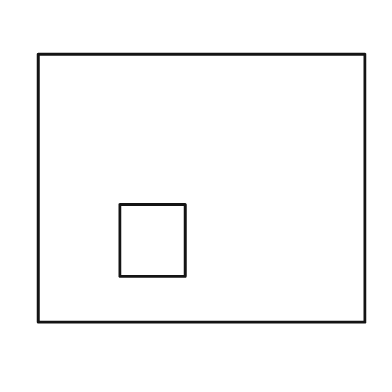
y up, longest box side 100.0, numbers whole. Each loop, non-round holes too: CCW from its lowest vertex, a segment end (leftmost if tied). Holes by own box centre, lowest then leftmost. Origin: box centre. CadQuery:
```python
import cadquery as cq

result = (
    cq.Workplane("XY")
    .moveTo(-50.0, -41.0)
    .lineTo(50.0, -41.0)
    .lineTo(50.0, 41.0)
    .lineTo(-50.0, 41.0)
    .close()
    .moveTo(-25.0, -27.0)
    .lineTo(-5.0, -27.0)
    .lineTo(-5.0, -5.0)
    .lineTo(-25.0, -5.0)
    .close()
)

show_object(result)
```